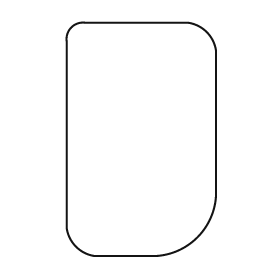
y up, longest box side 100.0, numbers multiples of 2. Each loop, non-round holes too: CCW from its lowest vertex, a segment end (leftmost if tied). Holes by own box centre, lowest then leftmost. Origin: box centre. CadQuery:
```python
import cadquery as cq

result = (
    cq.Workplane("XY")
    .moveTo(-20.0, -50.0)
    .lineTo(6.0, -50.0)
    .threePointArc((24.0, -42.0), (32.0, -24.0))
    .lineTo(32.0, 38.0)
    .threePointArc((28.0, 46.0), (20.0, 50.0))
    .lineTo(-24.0, 50.0)
    .threePointArc((-30.0, 48.0), (-32.0, 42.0))
    .lineTo(-32.0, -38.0)
    .threePointArc((-28.0, -46.0), (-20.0, -50.0))
    .close()
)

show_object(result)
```